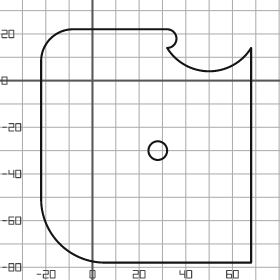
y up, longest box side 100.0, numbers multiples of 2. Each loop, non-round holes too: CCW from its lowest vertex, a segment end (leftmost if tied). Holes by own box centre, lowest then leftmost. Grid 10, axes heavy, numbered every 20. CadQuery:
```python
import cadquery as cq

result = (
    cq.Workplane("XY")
    .moveTo(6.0, -78.0)
    .lineTo(68.0, -78.0)
    .lineTo(68.0, 14.0)
    .threePointArc((50.0, 4.0), (32.0, 14.0))
    .threePointArc((36.0, 18.0), (32.0, 22.0))
    .lineTo(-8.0, 22.0)
    .threePointArc((-18.0, 18.0), (-22.0, 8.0))
    .lineTo(-22.0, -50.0)
    .threePointArc((-14.0, -70.0), (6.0, -78.0))
    .close()
    .moveTo(28.0, -30.0)
    .circle(4.0)
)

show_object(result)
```